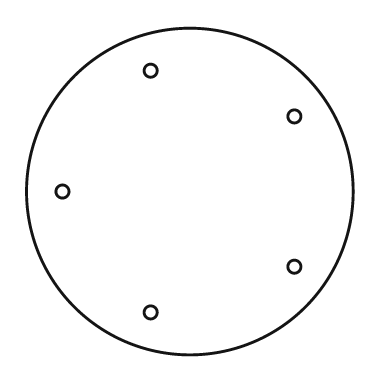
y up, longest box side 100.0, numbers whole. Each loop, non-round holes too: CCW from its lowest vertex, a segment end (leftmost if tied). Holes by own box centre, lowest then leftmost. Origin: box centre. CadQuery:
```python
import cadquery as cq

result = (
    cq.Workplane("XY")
    .moveTo(0.0, 0.0)
    .circle(50.0)
    .moveTo(-12.0, -37.0)
    .circle(2.0)
    .moveTo(32.0, -23.0)
    .circle(2.0)
    .moveTo(-39.0, 0.0)
    .circle(2.0)
    .moveTo(32.0, 23.0)
    .circle(2.0)
    .moveTo(-12.0, 37.0)
    .circle(2.0)
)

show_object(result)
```